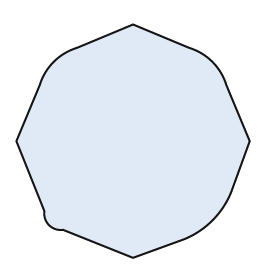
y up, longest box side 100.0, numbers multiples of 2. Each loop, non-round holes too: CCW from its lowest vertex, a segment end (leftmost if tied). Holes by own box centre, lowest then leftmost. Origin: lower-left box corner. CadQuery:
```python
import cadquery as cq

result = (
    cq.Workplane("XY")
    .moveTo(50.0, 0.0)
    .lineTo(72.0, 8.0)
    .threePointArc((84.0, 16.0), (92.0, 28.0))
    .lineTo(100.0, 50.0)
    .lineTo(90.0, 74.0)
    .threePointArc((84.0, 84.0), (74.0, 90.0))
    .lineTo(50.0, 100.0)
    .lineTo(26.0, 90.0)
    .threePointArc((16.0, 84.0), (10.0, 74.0))
    .lineTo(0.0, 50.0)
    .lineTo(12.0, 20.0)
    .threePointArc((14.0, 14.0), (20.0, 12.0))
    .close()
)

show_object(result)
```